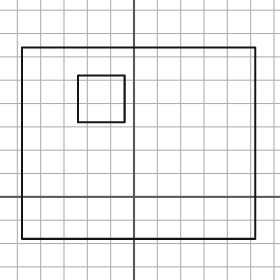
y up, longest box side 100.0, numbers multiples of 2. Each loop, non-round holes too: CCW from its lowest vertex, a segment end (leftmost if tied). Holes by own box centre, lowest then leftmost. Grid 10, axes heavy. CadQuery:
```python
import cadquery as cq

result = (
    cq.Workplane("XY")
    .moveTo(-48.0, -18.0)
    .lineTo(52.0, -18.0)
    .lineTo(52.0, 64.0)
    .lineTo(-48.0, 64.0)
    .close()
    .moveTo(-24.0, 32.0)
    .lineTo(-4.0, 32.0)
    .lineTo(-4.0, 52.0)
    .lineTo(-24.0, 52.0)
    .close()
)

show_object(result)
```